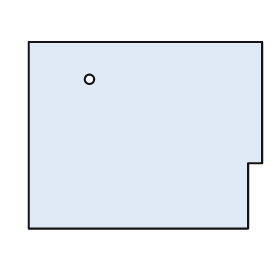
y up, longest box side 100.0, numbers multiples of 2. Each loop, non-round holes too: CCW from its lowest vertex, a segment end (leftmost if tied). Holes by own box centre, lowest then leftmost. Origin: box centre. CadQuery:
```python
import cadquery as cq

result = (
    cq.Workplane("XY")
    .moveTo(-50.0, -40.0)
    .lineTo(44.0, -40.0)
    .lineTo(44.0, -12.0)
    .lineTo(50.0, -12.0)
    .lineTo(50.0, 40.0)
    .lineTo(-50.0, 40.0)
    .close()
    .moveTo(-24.0, 24.0)
    .circle(2.0)
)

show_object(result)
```